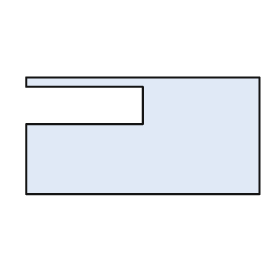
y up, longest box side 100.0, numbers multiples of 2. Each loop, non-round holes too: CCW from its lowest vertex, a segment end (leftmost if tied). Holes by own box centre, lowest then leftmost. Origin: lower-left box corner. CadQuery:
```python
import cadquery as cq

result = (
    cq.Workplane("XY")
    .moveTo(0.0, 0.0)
    .lineTo(100.0, 0.0)
    .lineTo(100.0, 50.0)
    .lineTo(0.0, 50.0)
    .lineTo(0.0, 46.0)
    .lineTo(50.0, 46.0)
    .lineTo(50.0, 30.0)
    .lineTo(0.0, 30.0)
    .close()
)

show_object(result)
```